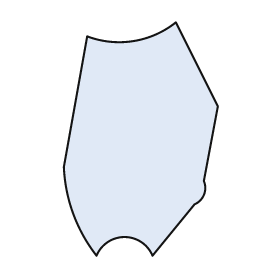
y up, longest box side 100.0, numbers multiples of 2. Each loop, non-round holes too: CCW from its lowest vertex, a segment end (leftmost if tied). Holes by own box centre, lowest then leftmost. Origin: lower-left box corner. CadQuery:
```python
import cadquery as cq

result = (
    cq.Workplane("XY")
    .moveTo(14.0, 0.0)
    .threePointArc((26.0, 8.0), (38.0, 0.0))
    .lineTo(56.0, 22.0)
    .threePointArc((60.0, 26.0), (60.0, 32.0))
    .lineTo(66.0, 64.0)
    .lineTo(48.0, 100.0)
    .threePointArc((30.0, 92.0), (10.0, 94.0))
    .lineTo(0.0, 38.0)
    .threePointArc((4.0, 18.0), (14.0, 0.0))
    .close()
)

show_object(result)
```